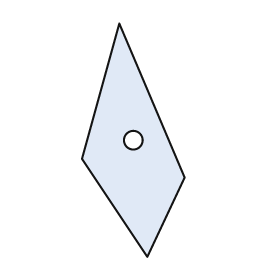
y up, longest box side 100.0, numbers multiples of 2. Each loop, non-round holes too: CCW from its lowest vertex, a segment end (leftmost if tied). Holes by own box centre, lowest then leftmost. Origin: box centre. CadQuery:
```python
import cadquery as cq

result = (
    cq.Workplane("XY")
    .moveTo(6.0, -50.0)
    .lineTo(22.0, -16.0)
    .lineTo(-6.0, 50.0)
    .lineTo(-22.0, -8.0)
    .close()
    .moveTo(0.0, 0.0)
    .circle(4.0)
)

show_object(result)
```